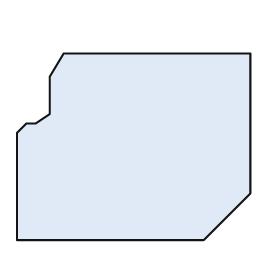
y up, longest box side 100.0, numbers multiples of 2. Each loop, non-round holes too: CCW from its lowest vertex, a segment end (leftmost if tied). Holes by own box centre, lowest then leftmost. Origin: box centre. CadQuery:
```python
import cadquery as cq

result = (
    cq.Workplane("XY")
    .moveTo(-50.0, -40.0)
    .lineTo(30.0, -40.0)
    .lineTo(50.0, -20.0)
    .lineTo(50.0, 40.0)
    .lineTo(-30.0, 40.0)
    .lineTo(-36.0, 30.0)
    .lineTo(-36.0, 14.0)
    .lineTo(-42.0, 10.0)
    .lineTo(-46.0, 10.0)
    .lineTo(-50.0, 6.0)
    .close()
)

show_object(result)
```